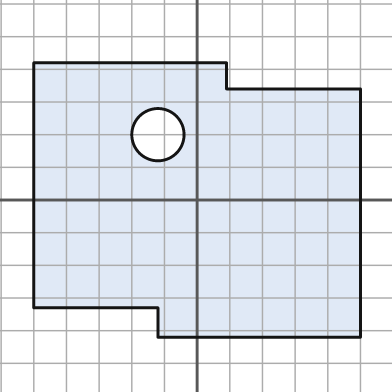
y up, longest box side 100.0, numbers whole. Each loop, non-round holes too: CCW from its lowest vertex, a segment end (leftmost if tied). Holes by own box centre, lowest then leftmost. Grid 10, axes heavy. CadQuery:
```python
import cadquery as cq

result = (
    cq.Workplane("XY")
    .moveTo(-12.0, -42.0)
    .lineTo(50.0, -42.0)
    .lineTo(50.0, 34.0)
    .lineTo(9.0, 34.0)
    .lineTo(9.0, 42.0)
    .lineTo(-50.0, 42.0)
    .lineTo(-50.0, -33.0)
    .lineTo(-12.0, -33.0)
    .close()
    .moveTo(-12.0, 20.0)
    .circle(8.0)
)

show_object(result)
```